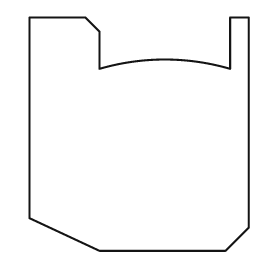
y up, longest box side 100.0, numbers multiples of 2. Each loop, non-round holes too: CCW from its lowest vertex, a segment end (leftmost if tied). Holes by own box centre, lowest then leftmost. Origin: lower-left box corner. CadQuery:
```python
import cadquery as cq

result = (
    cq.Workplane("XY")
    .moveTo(30.0, 0.0)
    .lineTo(84.0, 0.0)
    .lineTo(94.0, 10.0)
    .lineTo(94.0, 100.0)
    .lineTo(86.0, 100.0)
    .lineTo(86.0, 78.0)
    .threePointArc((58.0, 82.0), (30.0, 78.0))
    .lineTo(30.0, 94.0)
    .lineTo(24.0, 100.0)
    .lineTo(0.0, 100.0)
    .lineTo(0.0, 14.0)
    .close()
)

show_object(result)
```